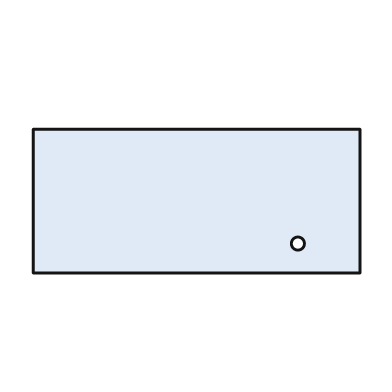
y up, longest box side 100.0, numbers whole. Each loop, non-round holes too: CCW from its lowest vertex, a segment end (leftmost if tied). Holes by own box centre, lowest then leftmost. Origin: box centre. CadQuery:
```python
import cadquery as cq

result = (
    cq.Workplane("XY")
    .moveTo(-50.0, -22.0)
    .lineTo(50.0, -22.0)
    .lineTo(50.0, 22.0)
    .lineTo(-50.0, 22.0)
    .close()
    .moveTo(31.0, -13.0)
    .circle(2.0)
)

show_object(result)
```